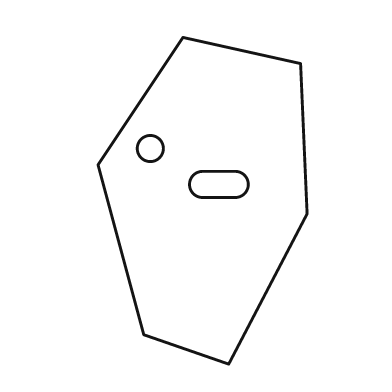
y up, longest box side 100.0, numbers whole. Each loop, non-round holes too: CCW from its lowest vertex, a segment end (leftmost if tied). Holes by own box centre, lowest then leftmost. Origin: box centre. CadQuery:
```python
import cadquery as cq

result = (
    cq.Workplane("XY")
    .moveTo(8.0, -50.0)
    .lineTo(32.0, -4.0)
    .lineTo(30.0, 42.0)
    .lineTo(-6.0, 50.0)
    .lineTo(-32.0, 11.0)
    .lineTo(-18.0, -41.0)
    .close()
    .moveTo(0.0, 1.0)
    .lineTo(10.0, 1.0)
    .threePointArc((14.0, 5.0), (10.0, 9.0))
    .lineTo(0.0, 9.0)
    .threePointArc((-4.0, 5.0), (0.0, 1.0))
    .close()
    .moveTo(-16.0, 16.0)
    .circle(4.0)
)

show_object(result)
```